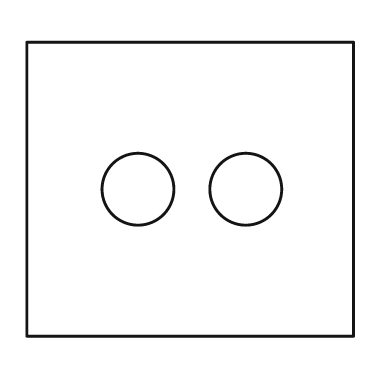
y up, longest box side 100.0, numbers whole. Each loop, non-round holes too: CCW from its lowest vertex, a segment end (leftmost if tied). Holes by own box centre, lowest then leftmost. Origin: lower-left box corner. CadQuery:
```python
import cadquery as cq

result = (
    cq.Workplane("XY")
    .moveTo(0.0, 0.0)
    .lineTo(100.0, 0.0)
    .lineTo(100.0, 90.0)
    .lineTo(0.0, 90.0)
    .close()
    .moveTo(34.0, 45.0)
    .circle(11.0)
    .moveTo(67.0, 45.0)
    .circle(11.0)
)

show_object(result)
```